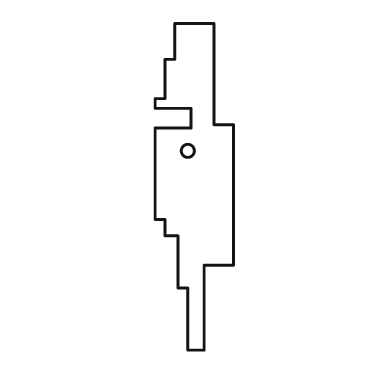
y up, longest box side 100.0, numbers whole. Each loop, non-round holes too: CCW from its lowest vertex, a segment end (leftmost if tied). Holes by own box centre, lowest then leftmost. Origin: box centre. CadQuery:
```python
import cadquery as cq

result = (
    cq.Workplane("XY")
    .moveTo(-2.0, -50.0)
    .lineTo(3.0, -50.0)
    .lineTo(3.0, -24.0)
    .lineTo(12.0, -24.0)
    .lineTo(12.0, 19.0)
    .lineTo(6.0, 19.0)
    .lineTo(6.0, 50.0)
    .lineTo(-6.0, 50.0)
    .lineTo(-6.0, 39.0)
    .lineTo(-9.0, 39.0)
    .lineTo(-9.0, 27.0)
    .lineTo(-12.0, 27.0)
    .lineTo(-12.0, 24.0)
    .lineTo(-1.0, 24.0)
    .lineTo(-1.0, 18.0)
    .lineTo(-12.0, 18.0)
    .lineTo(-12.0, -10.0)
    .lineTo(-9.0, -10.0)
    .lineTo(-9.0, -15.0)
    .lineTo(-5.0, -15.0)
    .lineTo(-5.0, -31.0)
    .lineTo(-2.0, -31.0)
    .close()
    .moveTo(-2.0, 11.0)
    .circle(2.0)
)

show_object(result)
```